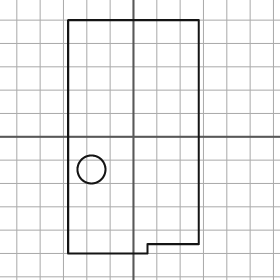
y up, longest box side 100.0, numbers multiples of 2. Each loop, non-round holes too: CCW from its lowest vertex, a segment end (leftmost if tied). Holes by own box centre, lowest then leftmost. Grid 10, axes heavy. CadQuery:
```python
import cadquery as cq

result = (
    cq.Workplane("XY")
    .moveTo(-28.0, -50.0)
    .lineTo(6.0, -50.0)
    .lineTo(6.0, -46.0)
    .lineTo(28.0, -46.0)
    .lineTo(28.0, 50.0)
    .lineTo(-28.0, 50.0)
    .close()
    .moveTo(-18.0, -14.0)
    .circle(6.0)
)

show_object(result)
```